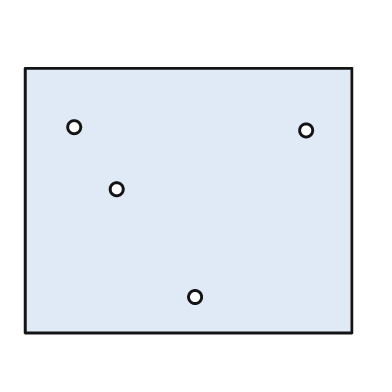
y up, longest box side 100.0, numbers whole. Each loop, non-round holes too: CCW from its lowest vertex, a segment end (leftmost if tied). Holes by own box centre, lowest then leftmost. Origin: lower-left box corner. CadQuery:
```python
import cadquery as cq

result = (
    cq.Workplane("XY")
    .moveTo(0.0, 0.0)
    .lineTo(100.0, 0.0)
    .lineTo(100.0, 81.0)
    .lineTo(0.0, 81.0)
    .close()
    .moveTo(52.0, 11.0)
    .circle(2.0)
    .moveTo(28.0, 44.0)
    .circle(2.0)
    .moveTo(86.0, 62.0)
    .circle(2.0)
    .moveTo(15.0, 63.0)
    .circle(2.0)
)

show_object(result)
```